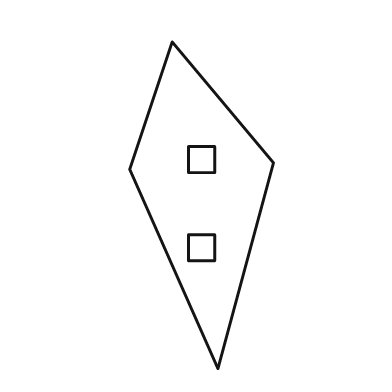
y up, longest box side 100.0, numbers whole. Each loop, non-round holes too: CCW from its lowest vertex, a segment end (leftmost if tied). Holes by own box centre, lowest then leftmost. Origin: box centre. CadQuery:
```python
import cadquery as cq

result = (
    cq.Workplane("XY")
    .moveTo(5.0, -50.0)
    .lineTo(22.0, 13.0)
    .lineTo(-9.0, 50.0)
    .lineTo(-22.0, 11.0)
    .close()
    .moveTo(-4.0, -17.0)
    .lineTo(4.0, -17.0)
    .lineTo(4.0, -9.0)
    .lineTo(-4.0, -9.0)
    .close()
    .moveTo(-4.0, 10.0)
    .lineTo(4.0, 10.0)
    .lineTo(4.0, 18.0)
    .lineTo(-4.0, 18.0)
    .close()
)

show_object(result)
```